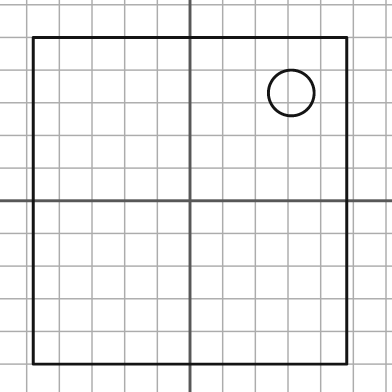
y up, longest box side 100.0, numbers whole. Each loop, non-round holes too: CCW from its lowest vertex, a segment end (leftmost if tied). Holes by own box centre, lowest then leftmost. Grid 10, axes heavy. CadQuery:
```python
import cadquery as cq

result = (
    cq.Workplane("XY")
    .moveTo(-48.0, -50.0)
    .lineTo(48.0, -50.0)
    .lineTo(48.0, 50.0)
    .lineTo(-48.0, 50.0)
    .close()
    .moveTo(31.0, 33.0)
    .circle(7.0)
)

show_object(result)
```